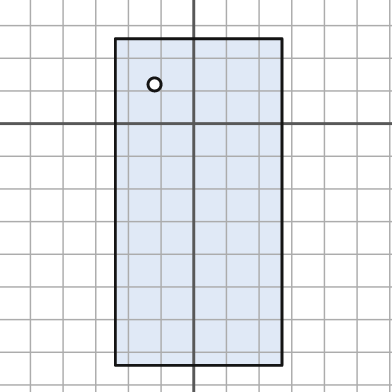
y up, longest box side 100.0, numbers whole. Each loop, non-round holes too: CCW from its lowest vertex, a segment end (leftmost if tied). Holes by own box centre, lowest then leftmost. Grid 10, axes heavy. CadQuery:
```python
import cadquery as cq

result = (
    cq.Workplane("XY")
    .moveTo(-24.0, -74.0)
    .lineTo(27.0, -74.0)
    .lineTo(27.0, 26.0)
    .lineTo(-24.0, 26.0)
    .close()
    .moveTo(-12.0, 12.0)
    .circle(2.0)
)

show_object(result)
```